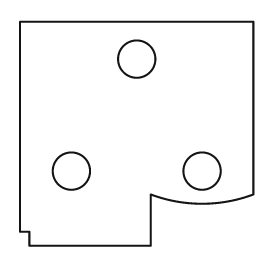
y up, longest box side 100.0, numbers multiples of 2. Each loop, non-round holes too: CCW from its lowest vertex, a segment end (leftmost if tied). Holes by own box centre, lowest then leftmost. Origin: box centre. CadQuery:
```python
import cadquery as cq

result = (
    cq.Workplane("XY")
    .moveTo(-46.0, -48.0)
    .lineTo(6.0, -48.0)
    .lineTo(6.0, -26.0)
    .threePointArc((28.0, -30.0), (50.0, -26.0))
    .lineTo(50.0, 48.0)
    .lineTo(-50.0, 48.0)
    .lineTo(-50.0, -42.0)
    .lineTo(-46.0, -42.0)
    .close()
    .moveTo(-28.0, -16.0)
    .circle(8.0)
    .moveTo(28.0, -16.0)
    .circle(8.0)
    .moveTo(0.0, 32.0)
    .circle(8.0)
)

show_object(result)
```